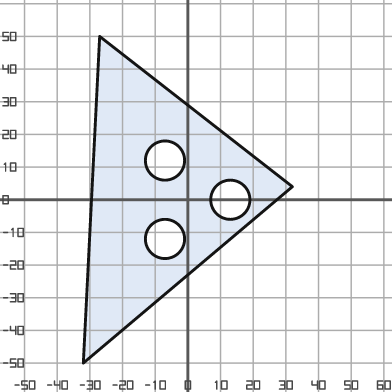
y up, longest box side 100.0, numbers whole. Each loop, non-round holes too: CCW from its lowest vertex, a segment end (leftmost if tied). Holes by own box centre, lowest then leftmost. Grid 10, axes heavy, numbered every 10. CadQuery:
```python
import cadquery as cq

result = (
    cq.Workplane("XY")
    .moveTo(-32.0, -50.0)
    .lineTo(32.0, 4.0)
    .lineTo(-27.0, 50.0)
    .close()
    .moveTo(-7.0, -12.0)
    .circle(6.0)
    .moveTo(13.0, 0.0)
    .circle(6.0)
    .moveTo(-7.0, 12.0)
    .circle(6.0)
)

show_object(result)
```